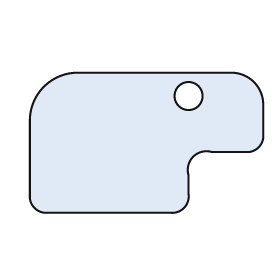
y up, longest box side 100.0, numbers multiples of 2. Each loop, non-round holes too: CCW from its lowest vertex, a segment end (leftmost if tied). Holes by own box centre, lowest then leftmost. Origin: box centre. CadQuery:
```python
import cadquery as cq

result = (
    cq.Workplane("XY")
    .moveTo(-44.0, -30.0)
    .lineTo(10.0, -30.0)
    .threePointArc((16.0, -28.0), (18.0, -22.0))
    .lineTo(18.0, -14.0)
    .threePointArc((20.0, -6.0), (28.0, -4.0))
    .lineTo(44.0, -4.0)
    .threePointArc((48.0, -2.0), (50.0, 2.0))
    .lineTo(50.0, 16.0)
    .threePointArc((46.0, 26.0), (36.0, 30.0))
    .lineTo(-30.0, 30.0)
    .threePointArc((-44.0, 24.0), (-50.0, 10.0))
    .lineTo(-50.0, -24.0)
    .threePointArc((-48.0, -28.0), (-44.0, -30.0))
    .close()
    .moveTo(18.0, 20.0)
    .circle(6.0)
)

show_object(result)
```